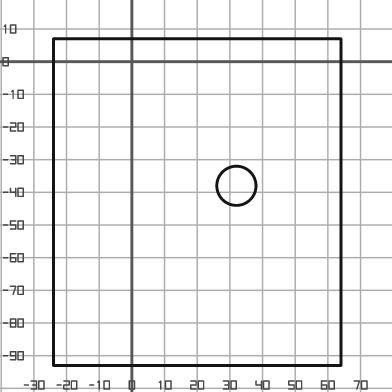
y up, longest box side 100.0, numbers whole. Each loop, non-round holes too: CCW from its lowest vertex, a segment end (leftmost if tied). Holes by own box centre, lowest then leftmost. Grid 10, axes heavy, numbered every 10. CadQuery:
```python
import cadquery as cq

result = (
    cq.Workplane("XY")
    .moveTo(-24.0, -93.0)
    .lineTo(64.0, -93.0)
    .lineTo(64.0, 7.0)
    .lineTo(-24.0, 7.0)
    .close()
    .moveTo(32.0, -38.0)
    .circle(6.0)
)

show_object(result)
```